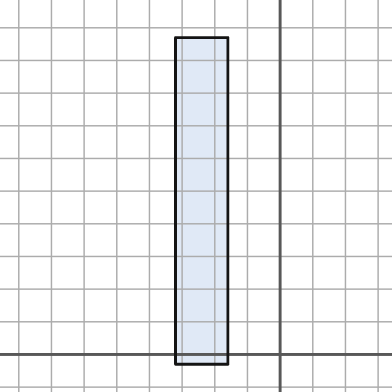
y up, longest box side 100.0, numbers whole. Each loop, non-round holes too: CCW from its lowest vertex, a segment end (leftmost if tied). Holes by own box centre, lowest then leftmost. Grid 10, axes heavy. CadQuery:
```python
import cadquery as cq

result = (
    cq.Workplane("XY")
    .moveTo(-32.0, -3.0)
    .lineTo(-16.0, -3.0)
    .lineTo(-16.0, 97.0)
    .lineTo(-32.0, 97.0)
    .close()
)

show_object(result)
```